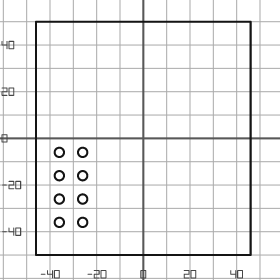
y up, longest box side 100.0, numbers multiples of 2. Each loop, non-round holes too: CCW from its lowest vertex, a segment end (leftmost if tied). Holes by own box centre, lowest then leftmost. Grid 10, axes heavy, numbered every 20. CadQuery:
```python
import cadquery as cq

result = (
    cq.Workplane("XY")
    .moveTo(-46.0, -50.0)
    .lineTo(46.0, -50.0)
    .lineTo(46.0, 50.0)
    .lineTo(-46.0, 50.0)
    .close()
    .moveTo(-36.0, -36.0)
    .circle(2.0)
    .moveTo(-26.0, -36.0)
    .circle(2.0)
    .moveTo(-36.0, -26.0)
    .circle(2.0)
    .moveTo(-26.0, -26.0)
    .circle(2.0)
    .moveTo(-36.0, -16.0)
    .circle(2.0)
    .moveTo(-26.0, -16.0)
    .circle(2.0)
    .moveTo(-36.0, -6.0)
    .circle(2.0)
    .moveTo(-26.0, -6.0)
    .circle(2.0)
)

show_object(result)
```